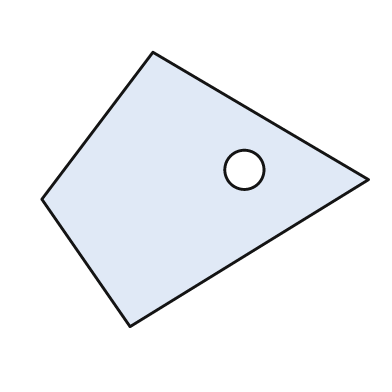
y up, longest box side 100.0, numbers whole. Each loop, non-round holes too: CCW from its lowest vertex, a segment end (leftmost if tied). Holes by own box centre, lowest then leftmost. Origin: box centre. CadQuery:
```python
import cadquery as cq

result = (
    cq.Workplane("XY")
    .moveTo(-23.0, -42.0)
    .lineTo(50.0, 3.0)
    .lineTo(-16.0, 42.0)
    .lineTo(-50.0, -3.0)
    .close()
    .moveTo(12.0, 6.0)
    .circle(6.0)
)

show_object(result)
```